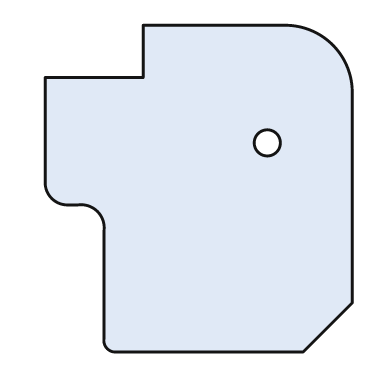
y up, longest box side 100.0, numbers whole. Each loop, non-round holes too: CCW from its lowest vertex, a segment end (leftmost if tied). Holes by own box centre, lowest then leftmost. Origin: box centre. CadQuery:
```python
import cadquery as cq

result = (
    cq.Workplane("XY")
    .moveTo(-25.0, -50.0)
    .lineTo(32.0, -50.0)
    .lineTo(47.0, -35.0)
    .lineTo(47.0, 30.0)
    .threePointArc((41.0, 44.0), (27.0, 50.0))
    .lineTo(-17.0, 50.0)
    .lineTo(-17.0, 34.0)
    .lineTo(-47.0, 34.0)
    .lineTo(-47.0, 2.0)
    .threePointArc((-45.0, -3.0), (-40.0, -5.0))
    .lineTo(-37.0, -5.0)
    .threePointArc((-31.0, -7.0), (-29.0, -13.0))
    .lineTo(-29.0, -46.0)
    .threePointArc((-28.0, -49.0), (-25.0, -50.0))
    .close()
    .moveTo(21.0, 14.0)
    .circle(4.0)
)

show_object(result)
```